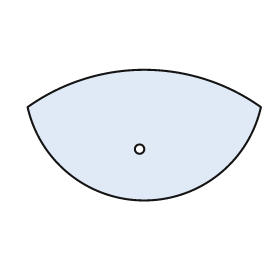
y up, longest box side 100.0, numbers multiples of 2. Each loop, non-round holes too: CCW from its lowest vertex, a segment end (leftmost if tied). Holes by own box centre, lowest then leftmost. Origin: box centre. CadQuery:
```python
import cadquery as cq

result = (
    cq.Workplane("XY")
    .moveTo(-50.0, 12.0)
    .threePointArc((0.0, -28.0), (50.0, 12.0))
    .threePointArc((0.0, 28.0), (-50.0, 12.0))
    .close()
    .moveTo(-2.0, -6.0)
    .circle(2.0)
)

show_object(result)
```